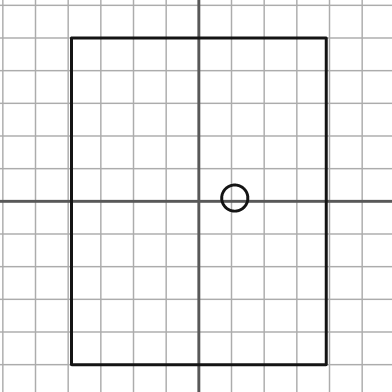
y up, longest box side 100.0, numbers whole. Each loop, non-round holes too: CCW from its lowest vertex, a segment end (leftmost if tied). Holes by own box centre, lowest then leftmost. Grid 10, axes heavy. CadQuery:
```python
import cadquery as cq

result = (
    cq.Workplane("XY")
    .moveTo(-39.0, -50.0)
    .lineTo(39.0, -50.0)
    .lineTo(39.0, 50.0)
    .lineTo(-39.0, 50.0)
    .close()
    .moveTo(11.0, 1.0)
    .circle(4.0)
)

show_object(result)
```